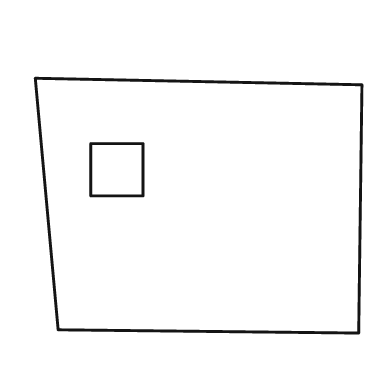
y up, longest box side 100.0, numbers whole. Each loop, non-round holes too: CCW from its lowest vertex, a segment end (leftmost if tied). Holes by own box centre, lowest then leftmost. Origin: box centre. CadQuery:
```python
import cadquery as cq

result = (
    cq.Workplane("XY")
    .moveTo(49.0, -39.0)
    .lineTo(50.0, 37.0)
    .lineTo(-50.0, 39.0)
    .lineTo(-43.0, -38.0)
    .close()
    .moveTo(-33.0, 3.0)
    .lineTo(-17.0, 3.0)
    .lineTo(-17.0, 19.0)
    .lineTo(-33.0, 19.0)
    .close()
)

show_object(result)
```